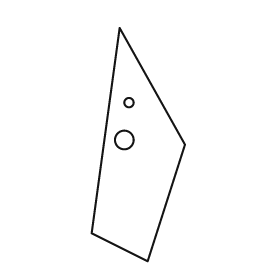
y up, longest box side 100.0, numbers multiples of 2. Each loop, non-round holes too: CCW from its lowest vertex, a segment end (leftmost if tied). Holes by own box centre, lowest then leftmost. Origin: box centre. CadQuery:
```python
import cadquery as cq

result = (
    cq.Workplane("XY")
    .moveTo(4.0, -50.0)
    .lineTo(20.0, 0.0)
    .lineTo(-8.0, 50.0)
    .lineTo(-20.0, -38.0)
    .close()
    .moveTo(-6.0, 2.0)
    .circle(4.0)
    .moveTo(-4.0, 18.0)
    .circle(2.0)
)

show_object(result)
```